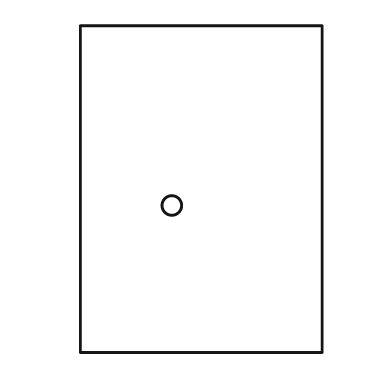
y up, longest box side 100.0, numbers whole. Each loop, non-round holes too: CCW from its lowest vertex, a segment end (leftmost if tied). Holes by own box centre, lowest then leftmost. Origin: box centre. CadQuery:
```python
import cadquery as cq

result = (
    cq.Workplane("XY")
    .moveTo(-37.0, -50.0)
    .lineTo(37.0, -50.0)
    .lineTo(37.0, 50.0)
    .lineTo(-37.0, 50.0)
    .close()
    .moveTo(-9.0, -5.0)
    .circle(3.0)
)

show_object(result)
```